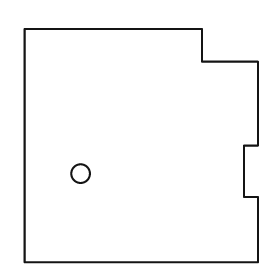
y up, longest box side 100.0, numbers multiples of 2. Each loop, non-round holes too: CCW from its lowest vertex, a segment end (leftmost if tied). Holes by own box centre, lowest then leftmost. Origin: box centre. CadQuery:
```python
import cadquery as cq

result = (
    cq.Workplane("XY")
    .moveTo(-50.0, -50.0)
    .lineTo(50.0, -50.0)
    .lineTo(50.0, -22.0)
    .lineTo(44.0, -22.0)
    .lineTo(44.0, 0.0)
    .lineTo(50.0, 0.0)
    .lineTo(50.0, 36.0)
    .lineTo(26.0, 36.0)
    .lineTo(26.0, 50.0)
    .lineTo(-50.0, 50.0)
    .close()
    .moveTo(-26.0, -12.0)
    .circle(4.0)
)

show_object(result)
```